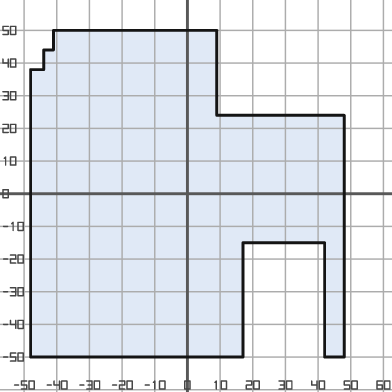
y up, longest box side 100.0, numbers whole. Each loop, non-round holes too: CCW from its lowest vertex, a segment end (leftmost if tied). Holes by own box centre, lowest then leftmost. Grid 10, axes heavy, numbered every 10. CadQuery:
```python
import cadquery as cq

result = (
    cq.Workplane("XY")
    .moveTo(-48.0, -50.0)
    .lineTo(17.0, -50.0)
    .lineTo(17.0, -15.0)
    .lineTo(42.0, -15.0)
    .lineTo(42.0, -50.0)
    .lineTo(48.0, -50.0)
    .lineTo(48.0, 24.0)
    .lineTo(9.0, 24.0)
    .lineTo(9.0, 50.0)
    .lineTo(-41.0, 50.0)
    .lineTo(-41.0, 44.0)
    .lineTo(-44.0, 44.0)
    .lineTo(-44.0, 38.0)
    .lineTo(-48.0, 38.0)
    .close()
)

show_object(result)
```